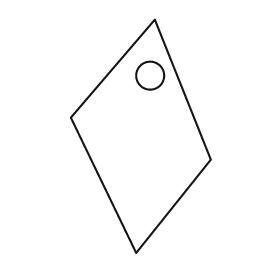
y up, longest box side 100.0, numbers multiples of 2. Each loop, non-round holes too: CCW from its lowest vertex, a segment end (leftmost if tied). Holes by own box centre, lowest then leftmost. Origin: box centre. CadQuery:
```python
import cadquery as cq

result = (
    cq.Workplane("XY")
    .moveTo(-2.0, -50.0)
    .lineTo(30.0, -10.0)
    .lineTo(6.0, 50.0)
    .lineTo(-30.0, 8.0)
    .close()
    .moveTo(4.0, 26.0)
    .circle(6.0)
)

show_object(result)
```